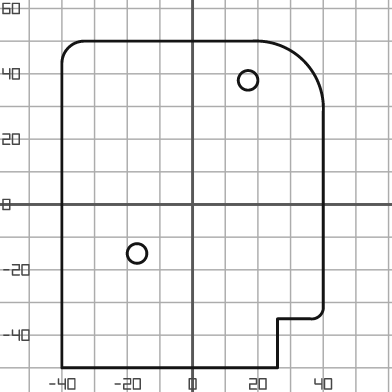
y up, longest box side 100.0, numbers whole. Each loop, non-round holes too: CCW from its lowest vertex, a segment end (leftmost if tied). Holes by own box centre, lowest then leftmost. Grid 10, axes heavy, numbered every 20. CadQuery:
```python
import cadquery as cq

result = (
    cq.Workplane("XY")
    .moveTo(-40.0, -50.0)
    .lineTo(26.0, -50.0)
    .lineTo(26.0, -35.0)
    .lineTo(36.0, -35.0)
    .threePointArc((39.0, -34.0), (40.0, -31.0))
    .lineTo(40.0, 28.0)
    .threePointArc((34.0, 44.0), (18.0, 50.0))
    .lineTo(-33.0, 50.0)
    .threePointArc((-38.0, 48.0), (-40.0, 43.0))
    .close()
    .moveTo(-17.0, -15.0)
    .circle(3.0)
    .moveTo(17.0, 38.0)
    .circle(3.0)
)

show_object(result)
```